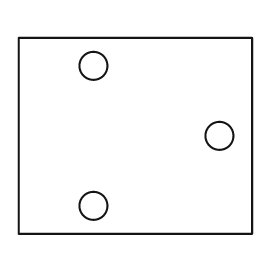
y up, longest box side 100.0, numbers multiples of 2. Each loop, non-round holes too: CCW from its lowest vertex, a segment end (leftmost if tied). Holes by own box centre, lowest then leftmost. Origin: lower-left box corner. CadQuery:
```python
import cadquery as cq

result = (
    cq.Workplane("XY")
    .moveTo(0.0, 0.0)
    .lineTo(100.0, 0.0)
    .lineTo(100.0, 84.0)
    .lineTo(0.0, 84.0)
    .close()
    .moveTo(32.0, 12.0)
    .circle(6.0)
    .moveTo(86.0, 42.0)
    .circle(6.0)
    .moveTo(32.0, 72.0)
    .circle(6.0)
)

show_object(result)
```